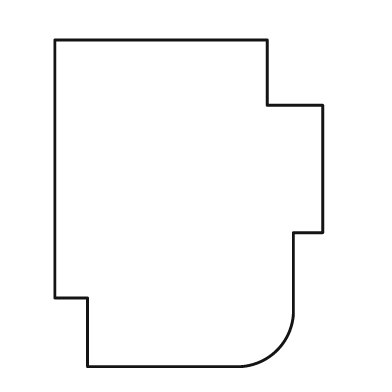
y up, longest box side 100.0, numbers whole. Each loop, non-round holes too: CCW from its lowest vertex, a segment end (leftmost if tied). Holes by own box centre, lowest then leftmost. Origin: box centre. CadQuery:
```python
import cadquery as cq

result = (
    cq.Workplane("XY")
    .moveTo(-31.0, -50.0)
    .lineTo(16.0, -50.0)
    .threePointArc((27.0, -45.0), (32.0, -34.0))
    .lineTo(32.0, -9.0)
    .lineTo(41.0, -9.0)
    .lineTo(41.0, 30.0)
    .lineTo(24.0, 30.0)
    .lineTo(24.0, 50.0)
    .lineTo(-41.0, 50.0)
    .lineTo(-41.0, -29.0)
    .lineTo(-31.0, -29.0)
    .close()
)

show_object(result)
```